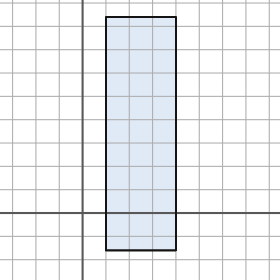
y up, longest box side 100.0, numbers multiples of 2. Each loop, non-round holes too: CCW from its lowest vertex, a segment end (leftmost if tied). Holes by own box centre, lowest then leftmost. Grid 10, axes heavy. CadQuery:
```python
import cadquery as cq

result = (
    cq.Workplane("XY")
    .moveTo(10.0, -16.0)
    .lineTo(40.0, -16.0)
    .lineTo(40.0, 84.0)
    .lineTo(10.0, 84.0)
    .close()
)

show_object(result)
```